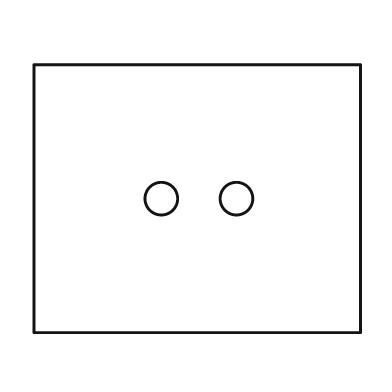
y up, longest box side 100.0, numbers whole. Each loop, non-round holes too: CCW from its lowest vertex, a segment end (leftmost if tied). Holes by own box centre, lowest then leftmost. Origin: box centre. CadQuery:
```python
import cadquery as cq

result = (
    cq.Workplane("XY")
    .moveTo(-50.0, -41.0)
    .lineTo(50.0, -41.0)
    .lineTo(50.0, 41.0)
    .lineTo(-50.0, 41.0)
    .close()
    .moveTo(-11.0, 0.0)
    .circle(5.0)
    .moveTo(12.0, 0.0)
    .circle(5.0)
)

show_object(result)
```